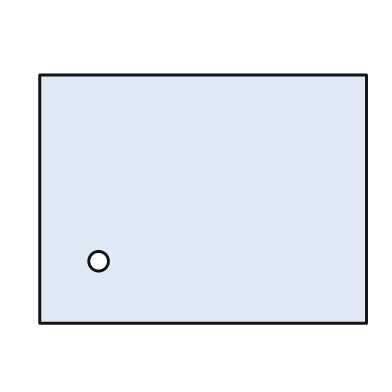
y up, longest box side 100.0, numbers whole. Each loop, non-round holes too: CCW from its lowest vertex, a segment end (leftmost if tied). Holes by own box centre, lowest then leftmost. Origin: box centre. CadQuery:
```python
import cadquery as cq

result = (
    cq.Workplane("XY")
    .moveTo(-50.0, -38.0)
    .lineTo(50.0, -38.0)
    .lineTo(50.0, 38.0)
    .lineTo(-50.0, 38.0)
    .close()
    .moveTo(-32.0, -19.0)
    .circle(3.0)
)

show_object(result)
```